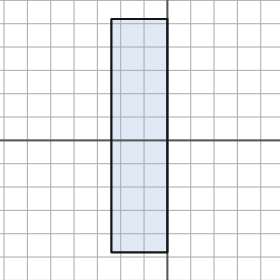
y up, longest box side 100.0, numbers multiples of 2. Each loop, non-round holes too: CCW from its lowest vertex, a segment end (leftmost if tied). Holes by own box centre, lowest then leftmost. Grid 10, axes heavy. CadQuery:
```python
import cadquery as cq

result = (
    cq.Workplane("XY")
    .moveTo(-24.0, -48.0)
    .lineTo(0.0, -48.0)
    .lineTo(0.0, 52.0)
    .lineTo(-24.0, 52.0)
    .close()
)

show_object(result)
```